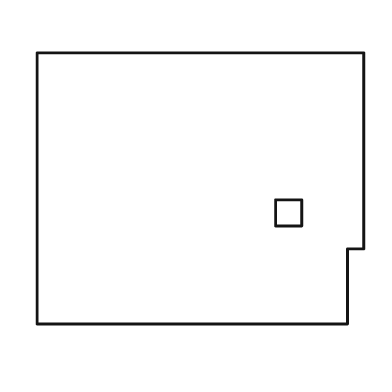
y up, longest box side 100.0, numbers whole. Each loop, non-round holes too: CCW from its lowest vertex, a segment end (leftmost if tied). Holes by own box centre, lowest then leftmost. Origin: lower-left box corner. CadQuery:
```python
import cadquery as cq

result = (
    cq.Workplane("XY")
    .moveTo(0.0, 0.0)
    .lineTo(95.0, 0.0)
    .lineTo(95.0, 23.0)
    .lineTo(100.0, 23.0)
    .lineTo(100.0, 83.0)
    .lineTo(0.0, 83.0)
    .close()
    .moveTo(73.0, 30.0)
    .lineTo(81.0, 30.0)
    .lineTo(81.0, 38.0)
    .lineTo(73.0, 38.0)
    .close()
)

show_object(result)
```